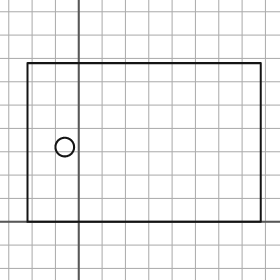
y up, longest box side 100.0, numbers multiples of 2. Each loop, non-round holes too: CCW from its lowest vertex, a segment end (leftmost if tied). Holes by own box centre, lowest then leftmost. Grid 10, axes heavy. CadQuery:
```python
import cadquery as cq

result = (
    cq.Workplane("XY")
    .moveTo(-22.0, 0.0)
    .lineTo(78.0, 0.0)
    .lineTo(78.0, 68.0)
    .lineTo(-22.0, 68.0)
    .close()
    .moveTo(-6.0, 32.0)
    .circle(4.0)
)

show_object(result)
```